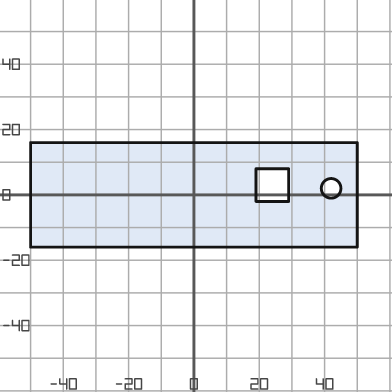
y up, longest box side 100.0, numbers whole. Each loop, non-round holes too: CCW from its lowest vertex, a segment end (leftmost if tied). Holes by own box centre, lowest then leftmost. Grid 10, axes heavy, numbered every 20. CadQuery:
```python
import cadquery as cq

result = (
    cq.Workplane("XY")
    .moveTo(-50.0, -16.0)
    .lineTo(50.0, -16.0)
    .lineTo(50.0, 16.0)
    .lineTo(-50.0, 16.0)
    .close()
    .moveTo(42.0, 2.0)
    .circle(3.0)
    .moveTo(19.0, -2.0)
    .lineTo(29.0, -2.0)
    .lineTo(29.0, 8.0)
    .lineTo(19.0, 8.0)
    .close()
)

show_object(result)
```